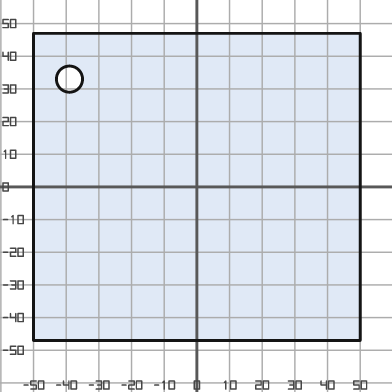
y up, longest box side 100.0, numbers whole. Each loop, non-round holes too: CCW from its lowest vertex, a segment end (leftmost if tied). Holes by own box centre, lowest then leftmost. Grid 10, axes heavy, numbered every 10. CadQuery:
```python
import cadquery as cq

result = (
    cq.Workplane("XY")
    .moveTo(-50.0, -47.0)
    .lineTo(50.0, -47.0)
    .lineTo(50.0, 47.0)
    .lineTo(-50.0, 47.0)
    .close()
    .moveTo(-39.0, 33.0)
    .circle(4.0)
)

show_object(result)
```